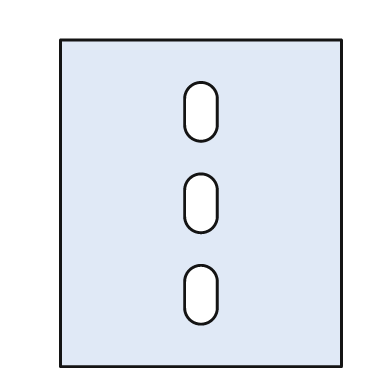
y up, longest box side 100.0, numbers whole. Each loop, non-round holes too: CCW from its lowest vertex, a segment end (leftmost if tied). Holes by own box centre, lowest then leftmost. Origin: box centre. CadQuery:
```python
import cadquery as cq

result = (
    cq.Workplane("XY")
    .moveTo(-43.0, -50.0)
    .lineTo(43.0, -50.0)
    .lineTo(43.0, 50.0)
    .lineTo(-43.0, 50.0)
    .close()
    .moveTo(-5.0, -32.0)
    .threePointArc((0.0, -37.0), (5.0, -32.0))
    .lineTo(5.0, -24.0)
    .threePointArc((0.0, -19.0), (-5.0, -24.0))
    .close()
    .moveTo(-5.0, -4.0)
    .threePointArc((0.0, -9.0), (5.0, -4.0))
    .lineTo(5.0, 4.0)
    .threePointArc((0.0, 9.0), (-5.0, 4.0))
    .close()
    .moveTo(-5.0, 24.0)
    .threePointArc((0.0, 19.0), (5.0, 24.0))
    .lineTo(5.0, 32.0)
    .threePointArc((0.0, 37.0), (-5.0, 32.0))
    .close()
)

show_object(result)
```